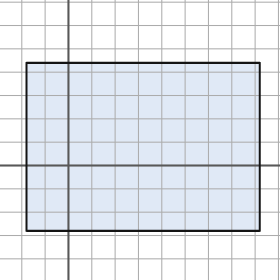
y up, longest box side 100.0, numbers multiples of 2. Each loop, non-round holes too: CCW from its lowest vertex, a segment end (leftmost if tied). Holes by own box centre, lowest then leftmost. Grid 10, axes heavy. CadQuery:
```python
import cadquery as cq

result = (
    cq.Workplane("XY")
    .moveTo(-18.0, -28.0)
    .lineTo(82.0, -28.0)
    .lineTo(82.0, 44.0)
    .lineTo(-18.0, 44.0)
    .close()
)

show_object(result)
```